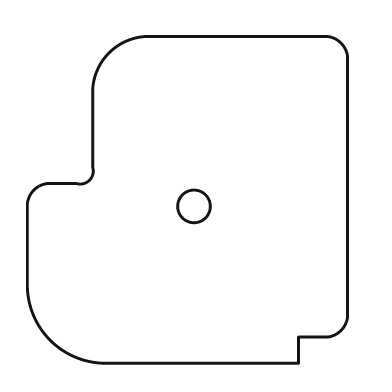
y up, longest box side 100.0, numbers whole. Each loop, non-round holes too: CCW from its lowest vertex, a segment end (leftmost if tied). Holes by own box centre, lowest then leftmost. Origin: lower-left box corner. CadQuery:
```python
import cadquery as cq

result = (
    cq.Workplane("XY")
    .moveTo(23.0, 0.0)
    .lineTo(83.0, 0.0)
    .lineTo(83.0, 8.0)
    .lineTo(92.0, 8.0)
    .threePointArc((96.0, 10.0), (98.0, 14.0))
    .lineTo(98.0, 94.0)
    .threePointArc((96.0, 98.0), (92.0, 100.0))
    .lineTo(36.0, 100.0)
    .threePointArc((25.0, 95.0), (20.0, 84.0))
    .lineTo(20.0, 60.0)
    .threePointArc((19.0, 56.0), (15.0, 55.0))
    .lineTo(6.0, 55.0)
    .threePointArc((2.0, 53.0), (0.0, 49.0))
    .lineTo(0.0, 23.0)
    .threePointArc((7.0, 7.0), (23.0, 0.0))
    .close()
    .moveTo(51.0, 48.0)
    .circle(5.0)
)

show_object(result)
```